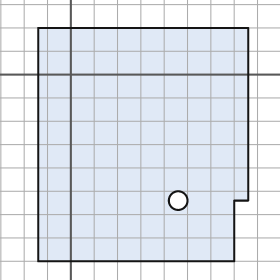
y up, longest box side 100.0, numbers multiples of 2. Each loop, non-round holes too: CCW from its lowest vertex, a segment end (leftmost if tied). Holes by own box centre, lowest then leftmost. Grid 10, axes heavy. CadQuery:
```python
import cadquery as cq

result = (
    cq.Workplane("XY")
    .moveTo(-14.0, -80.0)
    .lineTo(70.0, -80.0)
    .lineTo(70.0, -54.0)
    .lineTo(76.0, -54.0)
    .lineTo(76.0, 20.0)
    .lineTo(-14.0, 20.0)
    .close()
    .moveTo(46.0, -54.0)
    .circle(4.0)
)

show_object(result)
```